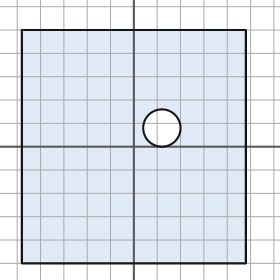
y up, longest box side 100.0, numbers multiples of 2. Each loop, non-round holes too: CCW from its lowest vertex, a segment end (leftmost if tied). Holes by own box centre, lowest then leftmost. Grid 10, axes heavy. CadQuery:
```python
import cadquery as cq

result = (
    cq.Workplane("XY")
    .moveTo(-48.0, -50.0)
    .lineTo(48.0, -50.0)
    .lineTo(48.0, 50.0)
    .lineTo(-48.0, 50.0)
    .close()
    .moveTo(12.0, 8.0)
    .circle(8.0)
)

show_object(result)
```